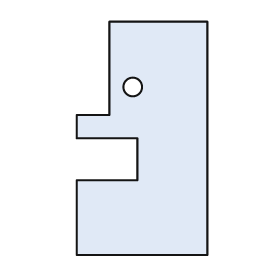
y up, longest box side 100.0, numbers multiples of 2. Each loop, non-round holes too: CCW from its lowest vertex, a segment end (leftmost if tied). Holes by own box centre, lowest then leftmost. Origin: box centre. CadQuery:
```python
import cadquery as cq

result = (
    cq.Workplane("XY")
    .moveTo(-28.0, -50.0)
    .lineTo(28.0, -50.0)
    .lineTo(28.0, 50.0)
    .lineTo(-14.0, 50.0)
    .lineTo(-14.0, 10.0)
    .lineTo(-28.0, 10.0)
    .lineTo(-28.0, 0.0)
    .lineTo(-2.0, 0.0)
    .lineTo(-2.0, -18.0)
    .lineTo(-28.0, -18.0)
    .close()
    .moveTo(-4.0, 22.0)
    .circle(4.0)
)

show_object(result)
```